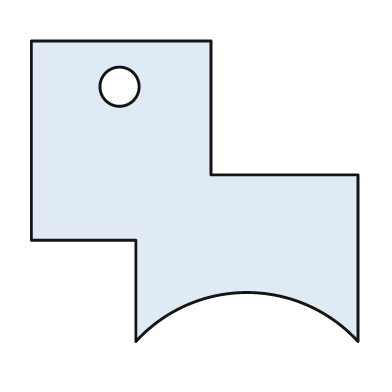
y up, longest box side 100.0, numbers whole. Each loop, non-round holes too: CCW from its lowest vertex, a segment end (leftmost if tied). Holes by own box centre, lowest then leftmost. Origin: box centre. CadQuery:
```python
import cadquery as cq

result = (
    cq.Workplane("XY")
    .moveTo(-18.0, -46.0)
    .threePointArc((16.0, -31.0), (50.0, -46.0))
    .lineTo(50.0, 5.0)
    .lineTo(5.0, 5.0)
    .lineTo(5.0, 46.0)
    .lineTo(-50.0, 46.0)
    .lineTo(-50.0, -15.0)
    .lineTo(-18.0, -15.0)
    .close()
    .moveTo(-23.0, 32.0)
    .circle(6.0)
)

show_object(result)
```